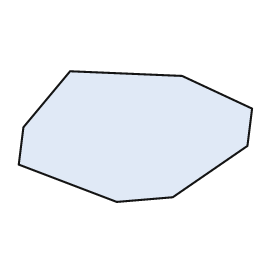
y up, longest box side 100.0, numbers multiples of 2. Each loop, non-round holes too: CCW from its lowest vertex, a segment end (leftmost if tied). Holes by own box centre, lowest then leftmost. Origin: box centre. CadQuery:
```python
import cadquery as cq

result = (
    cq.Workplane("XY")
    .moveTo(-8.0, -28.0)
    .lineTo(16.0, -26.0)
    .lineTo(48.0, -4.0)
    .lineTo(50.0, 12.0)
    .lineTo(20.0, 26.0)
    .lineTo(-28.0, 28.0)
    .lineTo(-48.0, 4.0)
    .lineTo(-50.0, -12.0)
    .close()
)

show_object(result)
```